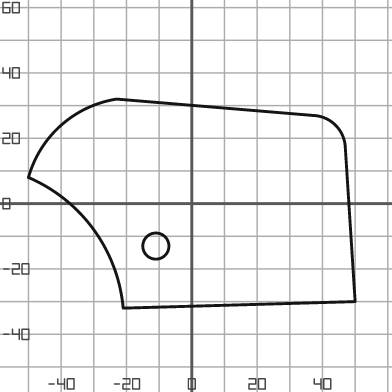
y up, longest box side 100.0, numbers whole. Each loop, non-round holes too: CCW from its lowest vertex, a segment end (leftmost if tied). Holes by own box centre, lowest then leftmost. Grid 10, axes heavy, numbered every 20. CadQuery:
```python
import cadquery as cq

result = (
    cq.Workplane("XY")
    .moveTo(-21.0, -32.0)
    .lineTo(50.0, -30.0)
    .lineTo(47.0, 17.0)
    .threePointArc((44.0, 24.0), (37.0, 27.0))
    .lineTo(-23.0, 32.0)
    .threePointArc((-40.0, 24.0), (-50.0, 8.0))
    .threePointArc((-30.0, -8.0), (-21.0, -32.0))
    .close()
    .moveTo(-11.0, -13.0)
    .circle(4.0)
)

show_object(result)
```